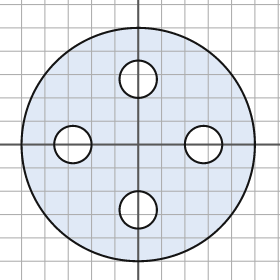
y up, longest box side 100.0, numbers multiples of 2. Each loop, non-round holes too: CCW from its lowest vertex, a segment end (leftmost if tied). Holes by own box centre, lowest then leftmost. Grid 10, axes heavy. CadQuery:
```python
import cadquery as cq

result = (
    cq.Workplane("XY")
    .moveTo(0.0, 0.0)
    .circle(50.0)
    .moveTo(0.0, -28.0)
    .circle(8.0)
    .moveTo(-28.0, 0.0)
    .circle(8.0)
    .moveTo(28.0, 0.0)
    .circle(8.0)
    .moveTo(0.0, 28.0)
    .circle(8.0)
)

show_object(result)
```